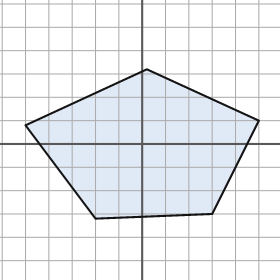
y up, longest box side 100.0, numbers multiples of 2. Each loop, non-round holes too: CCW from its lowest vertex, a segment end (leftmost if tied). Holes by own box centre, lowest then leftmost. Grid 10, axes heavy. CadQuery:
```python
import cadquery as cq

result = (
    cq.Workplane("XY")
    .moveTo(-20.0, -32.0)
    .lineTo(30.0, -30.0)
    .lineTo(50.0, 10.0)
    .lineTo(2.0, 32.0)
    .lineTo(-50.0, 8.0)
    .close()
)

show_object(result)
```